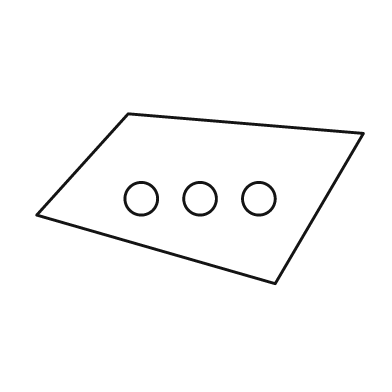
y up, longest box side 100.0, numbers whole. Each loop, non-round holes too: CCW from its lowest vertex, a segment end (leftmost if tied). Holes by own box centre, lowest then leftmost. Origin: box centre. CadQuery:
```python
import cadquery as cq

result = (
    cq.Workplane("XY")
    .moveTo(23.0, -26.0)
    .lineTo(50.0, 20.0)
    .lineTo(-22.0, 26.0)
    .lineTo(-50.0, -5.0)
    .close()
    .moveTo(-18.0, 0.0)
    .circle(5.0)
    .moveTo(0.0, 0.0)
    .circle(5.0)
    .moveTo(18.0, 0.0)
    .circle(5.0)
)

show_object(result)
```